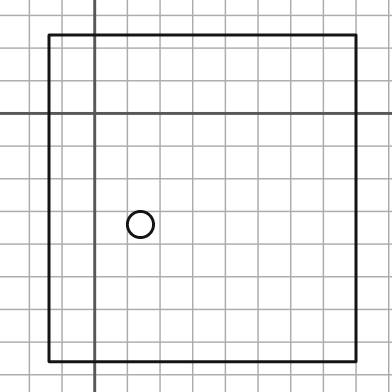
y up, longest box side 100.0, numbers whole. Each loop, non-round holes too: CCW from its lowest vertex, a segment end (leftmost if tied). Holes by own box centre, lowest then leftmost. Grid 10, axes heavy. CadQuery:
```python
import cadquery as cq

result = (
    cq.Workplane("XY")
    .moveTo(-14.0, -76.0)
    .lineTo(80.0, -76.0)
    .lineTo(80.0, 24.0)
    .lineTo(-14.0, 24.0)
    .close()
    .moveTo(14.0, -34.0)
    .circle(4.0)
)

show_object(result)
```